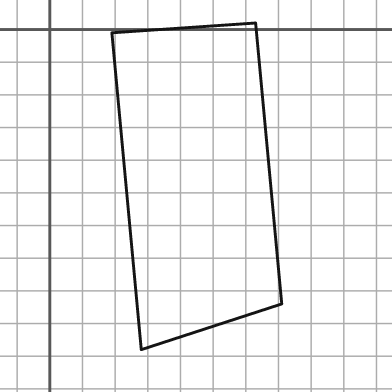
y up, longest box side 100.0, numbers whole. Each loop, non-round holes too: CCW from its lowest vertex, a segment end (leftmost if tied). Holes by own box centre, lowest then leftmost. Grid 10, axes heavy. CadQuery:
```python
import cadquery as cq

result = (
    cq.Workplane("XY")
    .moveTo(28.0, -98.0)
    .lineTo(71.0, -84.0)
    .lineTo(63.0, 2.0)
    .lineTo(19.0, -1.0)
    .close()
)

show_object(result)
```